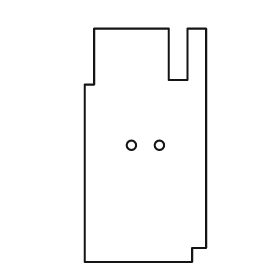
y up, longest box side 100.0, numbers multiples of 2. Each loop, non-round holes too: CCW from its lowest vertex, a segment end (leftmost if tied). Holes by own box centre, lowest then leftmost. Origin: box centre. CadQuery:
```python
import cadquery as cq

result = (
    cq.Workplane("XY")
    .moveTo(-26.0, -50.0)
    .lineTo(20.0, -50.0)
    .lineTo(20.0, -44.0)
    .lineTo(26.0, -44.0)
    .lineTo(26.0, 50.0)
    .lineTo(18.0, 50.0)
    .lineTo(18.0, 28.0)
    .lineTo(10.0, 28.0)
    .lineTo(10.0, 50.0)
    .lineTo(-22.0, 50.0)
    .lineTo(-22.0, 26.0)
    .lineTo(-26.0, 26.0)
    .close()
    .moveTo(-6.0, 0.0)
    .circle(2.0)
    .moveTo(6.0, 0.0)
    .circle(2.0)
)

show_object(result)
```